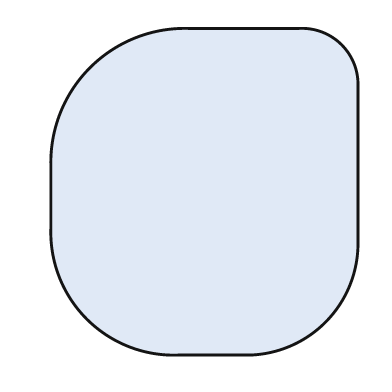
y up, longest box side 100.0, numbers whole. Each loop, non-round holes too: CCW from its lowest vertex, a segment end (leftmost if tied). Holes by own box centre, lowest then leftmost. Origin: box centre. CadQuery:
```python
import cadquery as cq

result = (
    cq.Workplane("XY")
    .moveTo(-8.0, -50.0)
    .lineTo(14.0, -50.0)
    .threePointArc((37.0, -40.0), (47.0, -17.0))
    .lineTo(47.0, 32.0)
    .threePointArc((42.0, 45.0), (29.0, 50.0))
    .lineTo(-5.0, 50.0)
    .threePointArc((-35.0, 38.0), (-47.0, 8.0))
    .lineTo(-47.0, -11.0)
    .threePointArc((-36.0, -39.0), (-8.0, -50.0))
    .close()
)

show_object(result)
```